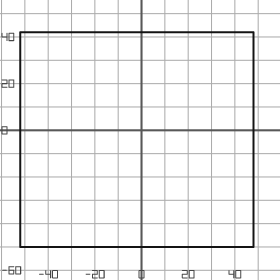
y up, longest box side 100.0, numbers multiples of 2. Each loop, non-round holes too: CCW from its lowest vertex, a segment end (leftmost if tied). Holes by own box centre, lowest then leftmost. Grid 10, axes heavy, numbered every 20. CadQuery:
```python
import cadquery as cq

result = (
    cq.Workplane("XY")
    .moveTo(-52.0, -50.0)
    .lineTo(48.0, -50.0)
    .lineTo(48.0, 42.0)
    .lineTo(-52.0, 42.0)
    .close()
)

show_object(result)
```